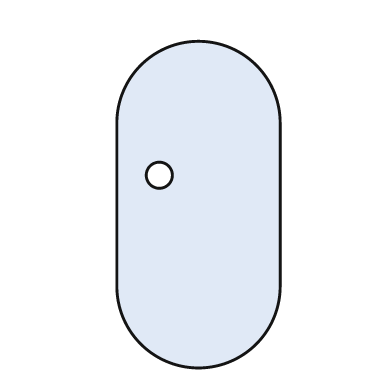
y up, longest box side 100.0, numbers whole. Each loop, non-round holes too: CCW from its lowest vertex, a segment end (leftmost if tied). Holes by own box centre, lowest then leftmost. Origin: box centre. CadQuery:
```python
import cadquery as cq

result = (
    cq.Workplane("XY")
    .moveTo(-25.0, -25.0)
    .threePointArc((0.0, -50.0), (25.0, -25.0))
    .lineTo(25.0, 25.0)
    .threePointArc((0.0, 50.0), (-25.0, 25.0))
    .close()
    .moveTo(-12.0, 9.0)
    .circle(4.0)
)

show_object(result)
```